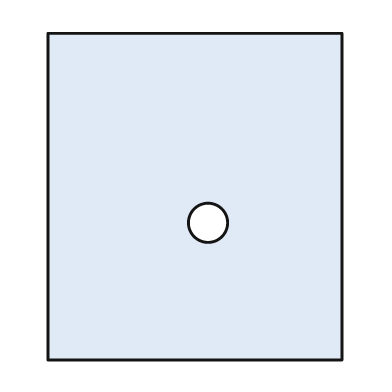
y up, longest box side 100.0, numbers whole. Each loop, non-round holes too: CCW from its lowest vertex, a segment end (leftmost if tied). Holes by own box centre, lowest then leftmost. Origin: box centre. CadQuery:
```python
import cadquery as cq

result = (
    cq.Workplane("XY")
    .moveTo(-45.0, -50.0)
    .lineTo(45.0, -50.0)
    .lineTo(45.0, 50.0)
    .lineTo(-45.0, 50.0)
    .close()
    .moveTo(4.0, -8.0)
    .circle(6.0)
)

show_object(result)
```